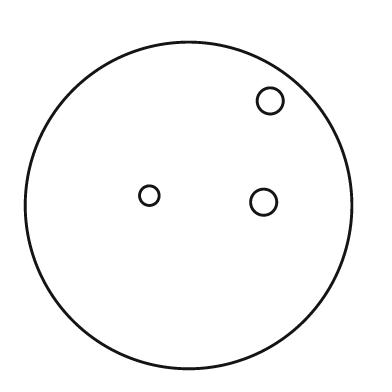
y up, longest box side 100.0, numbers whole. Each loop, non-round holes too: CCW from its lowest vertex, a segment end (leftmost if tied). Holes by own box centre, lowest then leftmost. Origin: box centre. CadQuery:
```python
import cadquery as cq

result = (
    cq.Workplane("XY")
    .moveTo(0.0, 0.0)
    .circle(50.0)
    .moveTo(23.0, 1.0)
    .circle(4.0)
    .moveTo(-12.0, 3.0)
    .circle(3.0)
    .moveTo(25.0, 32.0)
    .circle(4.0)
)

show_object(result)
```